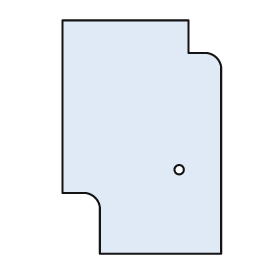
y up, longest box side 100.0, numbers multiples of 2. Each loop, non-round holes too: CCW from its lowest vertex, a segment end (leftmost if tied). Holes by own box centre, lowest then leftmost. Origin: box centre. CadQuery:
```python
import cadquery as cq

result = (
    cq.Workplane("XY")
    .moveTo(-18.0, -50.0)
    .lineTo(34.0, -50.0)
    .lineTo(34.0, 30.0)
    .threePointArc((32.0, 34.0), (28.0, 36.0))
    .lineTo(20.0, 36.0)
    .lineTo(20.0, 50.0)
    .lineTo(-34.0, 50.0)
    .lineTo(-34.0, -24.0)
    .lineTo(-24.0, -24.0)
    .threePointArc((-20.0, -26.0), (-18.0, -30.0))
    .close()
    .moveTo(16.0, -14.0)
    .circle(2.0)
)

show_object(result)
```